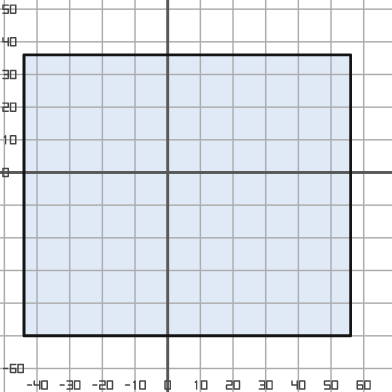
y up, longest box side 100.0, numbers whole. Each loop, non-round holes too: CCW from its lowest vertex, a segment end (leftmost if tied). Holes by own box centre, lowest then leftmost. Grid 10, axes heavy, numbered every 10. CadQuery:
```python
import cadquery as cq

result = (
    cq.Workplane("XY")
    .moveTo(-44.0, -50.0)
    .lineTo(56.0, -50.0)
    .lineTo(56.0, 36.0)
    .lineTo(-44.0, 36.0)
    .close()
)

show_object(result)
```